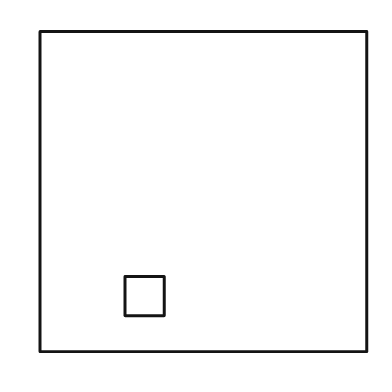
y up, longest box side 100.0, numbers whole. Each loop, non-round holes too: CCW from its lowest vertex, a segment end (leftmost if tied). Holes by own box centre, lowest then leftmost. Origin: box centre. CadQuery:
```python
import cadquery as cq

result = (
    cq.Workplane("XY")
    .moveTo(-50.0, -49.0)
    .lineTo(50.0, -49.0)
    .lineTo(50.0, 49.0)
    .lineTo(-50.0, 49.0)
    .close()
    .moveTo(-24.0, -38.0)
    .lineTo(-12.0, -38.0)
    .lineTo(-12.0, -26.0)
    .lineTo(-24.0, -26.0)
    .close()
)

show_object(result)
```